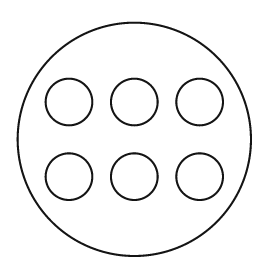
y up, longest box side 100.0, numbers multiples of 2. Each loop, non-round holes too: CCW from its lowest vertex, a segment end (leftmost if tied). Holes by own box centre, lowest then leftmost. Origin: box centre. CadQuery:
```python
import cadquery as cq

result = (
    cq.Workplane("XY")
    .moveTo(0.0, 0.0)
    .circle(50.0)
    .moveTo(-28.0, -16.0)
    .circle(10.0)
    .moveTo(0.0, -16.0)
    .circle(10.0)
    .moveTo(28.0, -16.0)
    .circle(10.0)
    .moveTo(-28.0, 16.0)
    .circle(10.0)
    .moveTo(0.0, 16.0)
    .circle(10.0)
    .moveTo(28.0, 16.0)
    .circle(10.0)
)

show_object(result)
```